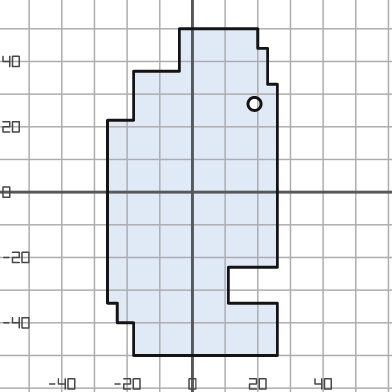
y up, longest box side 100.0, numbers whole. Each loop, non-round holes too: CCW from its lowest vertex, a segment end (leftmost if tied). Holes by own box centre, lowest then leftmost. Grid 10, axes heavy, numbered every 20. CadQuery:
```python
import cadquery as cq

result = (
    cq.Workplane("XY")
    .moveTo(-18.0, -50.0)
    .lineTo(26.0, -50.0)
    .lineTo(26.0, -34.0)
    .lineTo(11.0, -34.0)
    .lineTo(11.0, -23.0)
    .lineTo(26.0, -23.0)
    .lineTo(26.0, 33.0)
    .lineTo(23.0, 33.0)
    .lineTo(23.0, 44.0)
    .lineTo(20.0, 44.0)
    .lineTo(20.0, 50.0)
    .lineTo(-4.0, 50.0)
    .lineTo(-4.0, 37.0)
    .lineTo(-18.0, 37.0)
    .lineTo(-18.0, 22.0)
    .lineTo(-26.0, 22.0)
    .lineTo(-26.0, -34.0)
    .lineTo(-23.0, -34.0)
    .lineTo(-23.0, -40.0)
    .lineTo(-18.0, -40.0)
    .close()
    .moveTo(19.0, 27.0)
    .circle(2.0)
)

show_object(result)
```